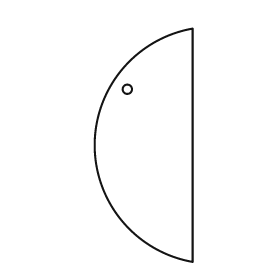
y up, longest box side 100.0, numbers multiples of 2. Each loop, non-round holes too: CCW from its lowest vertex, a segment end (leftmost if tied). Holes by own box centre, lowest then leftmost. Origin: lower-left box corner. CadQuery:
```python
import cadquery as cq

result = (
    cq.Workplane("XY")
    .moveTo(42.0, 0.0)
    .lineTo(42.0, 100.0)
    .threePointArc((0.0, 50.0), (42.0, 0.0))
    .close()
    .moveTo(14.0, 74.0)
    .circle(2.0)
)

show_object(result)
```